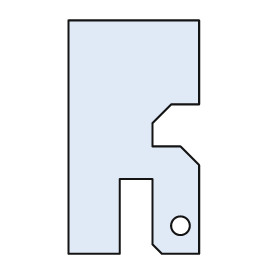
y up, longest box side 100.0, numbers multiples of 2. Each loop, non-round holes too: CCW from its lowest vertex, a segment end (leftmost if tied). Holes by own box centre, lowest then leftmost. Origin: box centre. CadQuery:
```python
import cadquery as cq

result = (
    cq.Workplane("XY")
    .moveTo(-28.0, -50.0)
    .lineTo(-6.0, -50.0)
    .lineTo(-6.0, -18.0)
    .lineTo(8.0, -18.0)
    .lineTo(8.0, -46.0)
    .lineTo(12.0, -50.0)
    .lineTo(28.0, -50.0)
    .lineTo(28.0, -12.0)
    .lineTo(20.0, -4.0)
    .lineTo(8.0, -4.0)
    .lineTo(8.0, 6.0)
    .lineTo(16.0, 14.0)
    .lineTo(28.0, 14.0)
    .lineTo(28.0, 50.0)
    .lineTo(-28.0, 50.0)
    .close()
    .moveTo(20.0, -38.0)
    .circle(4.0)
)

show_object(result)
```